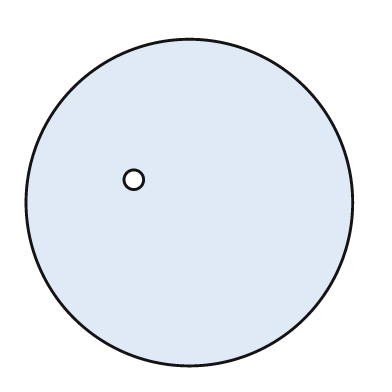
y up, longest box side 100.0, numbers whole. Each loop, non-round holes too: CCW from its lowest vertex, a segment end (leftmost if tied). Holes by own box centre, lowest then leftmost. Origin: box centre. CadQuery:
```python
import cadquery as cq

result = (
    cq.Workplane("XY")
    .moveTo(0.0, 0.0)
    .circle(50.0)
    .moveTo(-17.0, 7.0)
    .circle(3.0)
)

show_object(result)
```